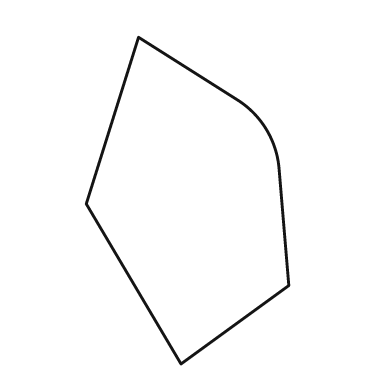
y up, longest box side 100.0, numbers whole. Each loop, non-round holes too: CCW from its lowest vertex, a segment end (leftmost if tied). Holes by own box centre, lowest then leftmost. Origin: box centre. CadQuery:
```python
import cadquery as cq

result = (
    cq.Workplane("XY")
    .moveTo(-2.0, -50.0)
    .lineTo(31.0, -26.0)
    .lineTo(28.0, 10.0)
    .threePointArc((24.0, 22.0), (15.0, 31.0))
    .lineTo(-15.0, 50.0)
    .lineTo(-31.0, -1.0)
    .close()
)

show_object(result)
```